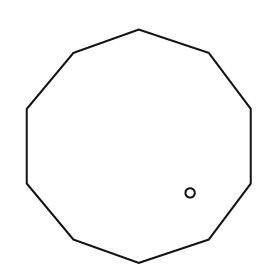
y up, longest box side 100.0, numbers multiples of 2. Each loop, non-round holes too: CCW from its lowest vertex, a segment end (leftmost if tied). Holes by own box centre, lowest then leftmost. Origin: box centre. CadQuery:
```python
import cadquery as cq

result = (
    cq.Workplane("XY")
    .moveTo(0.0, -50.0)
    .lineTo(30.0, -40.0)
    .lineTo(48.0, -16.0)
    .lineTo(48.0, 16.0)
    .lineTo(30.0, 40.0)
    .lineTo(0.0, 50.0)
    .lineTo(-28.0, 40.0)
    .lineTo(-48.0, 16.0)
    .lineTo(-48.0, -16.0)
    .lineTo(-28.0, -40.0)
    .close()
    .moveTo(22.0, -20.0)
    .circle(2.0)
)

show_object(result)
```